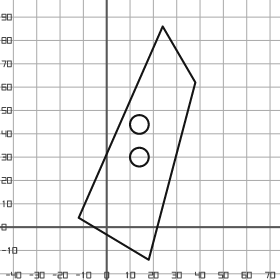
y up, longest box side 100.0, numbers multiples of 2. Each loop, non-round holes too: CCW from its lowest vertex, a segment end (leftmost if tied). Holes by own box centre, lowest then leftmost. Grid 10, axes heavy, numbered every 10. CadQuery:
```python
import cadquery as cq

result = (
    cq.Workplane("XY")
    .moveTo(18.0, -14.0)
    .lineTo(38.0, 62.0)
    .lineTo(24.0, 86.0)
    .lineTo(-12.0, 4.0)
    .close()
    .moveTo(14.0, 30.0)
    .circle(4.0)
    .moveTo(14.0, 44.0)
    .circle(4.0)
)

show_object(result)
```